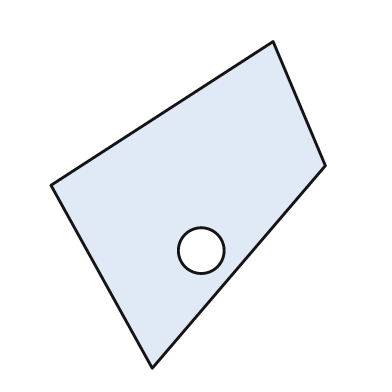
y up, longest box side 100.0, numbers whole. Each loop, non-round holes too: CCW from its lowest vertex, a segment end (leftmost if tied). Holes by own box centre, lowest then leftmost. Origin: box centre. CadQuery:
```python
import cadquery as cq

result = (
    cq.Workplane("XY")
    .moveTo(-11.0, -50.0)
    .lineTo(42.0, 12.0)
    .lineTo(26.0, 50.0)
    .lineTo(-42.0, 6.0)
    .close()
    .moveTo(4.0, -14.0)
    .circle(7.0)
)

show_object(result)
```